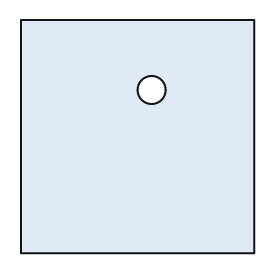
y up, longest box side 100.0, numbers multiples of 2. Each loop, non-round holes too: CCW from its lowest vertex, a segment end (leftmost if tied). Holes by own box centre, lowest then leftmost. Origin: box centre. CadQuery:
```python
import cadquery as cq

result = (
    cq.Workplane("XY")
    .moveTo(-50.0, -50.0)
    .lineTo(50.0, -50.0)
    .lineTo(50.0, 50.0)
    .lineTo(-50.0, 50.0)
    .close()
    .moveTo(6.0, 20.0)
    .circle(6.0)
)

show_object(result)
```